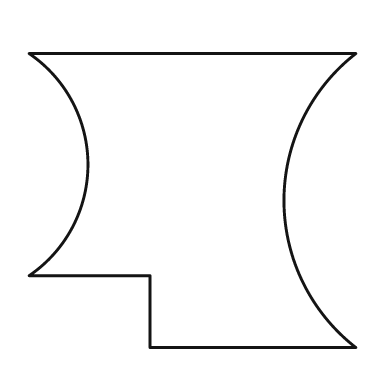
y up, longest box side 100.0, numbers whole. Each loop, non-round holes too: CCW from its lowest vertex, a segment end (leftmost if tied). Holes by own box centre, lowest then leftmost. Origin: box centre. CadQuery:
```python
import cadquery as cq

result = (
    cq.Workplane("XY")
    .moveTo(-13.0, -45.0)
    .lineTo(50.0, -45.0)
    .threePointArc((28.0, 0.0), (50.0, 45.0))
    .lineTo(-50.0, 45.0)
    .threePointArc((-32.0, 11.0), (-50.0, -23.0))
    .lineTo(-13.0, -23.0)
    .close()
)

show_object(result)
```